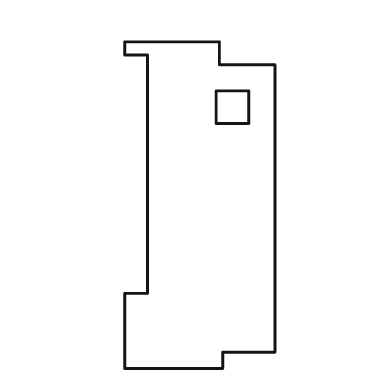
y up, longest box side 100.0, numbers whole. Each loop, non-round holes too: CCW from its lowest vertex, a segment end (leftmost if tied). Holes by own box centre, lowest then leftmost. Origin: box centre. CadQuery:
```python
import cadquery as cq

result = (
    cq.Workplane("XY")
    .moveTo(-23.0, -50.0)
    .lineTo(7.0, -50.0)
    .lineTo(7.0, -45.0)
    .lineTo(23.0, -45.0)
    .lineTo(23.0, 43.0)
    .lineTo(6.0, 43.0)
    .lineTo(6.0, 50.0)
    .lineTo(-23.0, 50.0)
    .lineTo(-23.0, 46.0)
    .lineTo(-16.0, 46.0)
    .lineTo(-16.0, -27.0)
    .lineTo(-23.0, -27.0)
    .close()
    .moveTo(5.0, 25.0)
    .lineTo(15.0, 25.0)
    .lineTo(15.0, 35.0)
    .lineTo(5.0, 35.0)
    .close()
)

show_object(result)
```